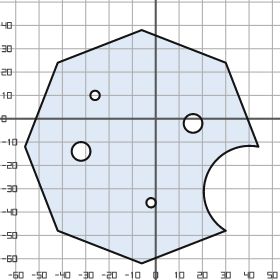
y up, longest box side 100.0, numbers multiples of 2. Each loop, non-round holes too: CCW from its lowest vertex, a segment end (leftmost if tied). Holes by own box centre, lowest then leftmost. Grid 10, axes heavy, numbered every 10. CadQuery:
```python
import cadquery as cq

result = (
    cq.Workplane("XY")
    .moveTo(-6.0, -62.0)
    .lineTo(30.0, -48.0)
    .threePointArc((22.0, -24.0), (44.0, -12.0))
    .lineTo(30.0, 24.0)
    .lineTo(-6.0, 38.0)
    .lineTo(-42.0, 24.0)
    .lineTo(-56.0, -12.0)
    .lineTo(-42.0, -48.0)
    .close()
    .moveTo(-2.0, -36.0)
    .circle(2.0)
    .moveTo(-32.0, -14.0)
    .circle(4.0)
    .moveTo(16.0, -2.0)
    .circle(4.0)
    .moveTo(-26.0, 10.0)
    .circle(2.0)
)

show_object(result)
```